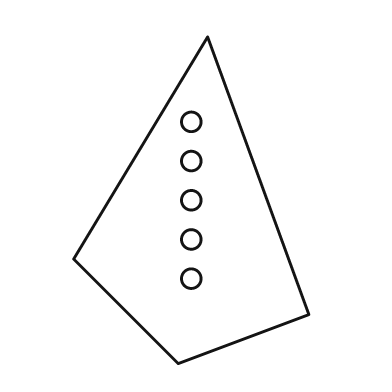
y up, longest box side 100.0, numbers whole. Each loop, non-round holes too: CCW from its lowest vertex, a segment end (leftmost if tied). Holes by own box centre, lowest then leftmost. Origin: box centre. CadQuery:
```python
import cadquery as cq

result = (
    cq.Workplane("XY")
    .moveTo(-4.0, -50.0)
    .lineTo(36.0, -35.0)
    .lineTo(5.0, 50.0)
    .lineTo(-36.0, -18.0)
    .close()
    .moveTo(0.0, -24.0)
    .circle(3.0)
    .moveTo(0.0, -12.0)
    .circle(3.0)
    .moveTo(0.0, 0.0)
    .circle(3.0)
    .moveTo(0.0, 12.0)
    .circle(3.0)
    .moveTo(0.0, 24.0)
    .circle(3.0)
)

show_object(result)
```